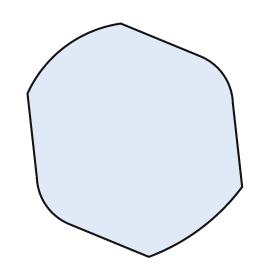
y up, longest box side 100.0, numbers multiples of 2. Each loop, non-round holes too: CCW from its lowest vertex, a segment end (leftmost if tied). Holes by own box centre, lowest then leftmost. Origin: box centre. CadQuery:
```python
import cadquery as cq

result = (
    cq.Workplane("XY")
    .moveTo(6.0, -50.0)
    .threePointArc((28.0, -38.0), (46.0, -20.0))
    .lineTo(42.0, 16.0)
    .threePointArc((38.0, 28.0), (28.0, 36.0))
    .lineTo(-6.0, 50.0)
    .threePointArc((-30.0, 40.0), (-46.0, 20.0))
    .lineTo(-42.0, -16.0)
    .threePointArc((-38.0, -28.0), (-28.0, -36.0))
    .close()
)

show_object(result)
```